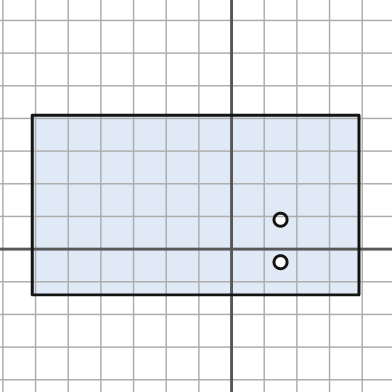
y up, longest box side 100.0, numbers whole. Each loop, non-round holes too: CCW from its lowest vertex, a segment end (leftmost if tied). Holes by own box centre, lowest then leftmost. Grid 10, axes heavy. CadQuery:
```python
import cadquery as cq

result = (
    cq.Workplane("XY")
    .moveTo(-61.0, -14.0)
    .lineTo(39.0, -14.0)
    .lineTo(39.0, 41.0)
    .lineTo(-61.0, 41.0)
    .close()
    .moveTo(15.0, -4.0)
    .circle(2.0)
    .moveTo(15.0, 9.0)
    .circle(2.0)
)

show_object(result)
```